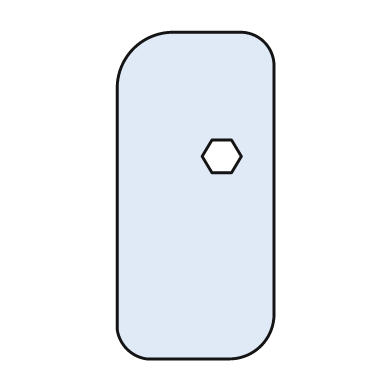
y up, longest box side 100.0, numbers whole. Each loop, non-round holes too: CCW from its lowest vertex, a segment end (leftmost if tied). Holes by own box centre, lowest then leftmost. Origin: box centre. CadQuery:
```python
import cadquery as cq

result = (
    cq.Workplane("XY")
    .moveTo(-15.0, -50.0)
    .lineTo(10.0, -50.0)
    .threePointArc((20.0, -46.0), (24.0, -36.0))
    .lineTo(24.0, 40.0)
    .threePointArc((21.0, 47.0), (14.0, 50.0))
    .lineTo(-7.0, 50.0)
    .threePointArc((-19.0, 45.0), (-24.0, 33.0))
    .lineTo(-24.0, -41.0)
    .threePointArc((-21.0, -47.0), (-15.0, -50.0))
    .close()
    .moveTo(5.0, 7.0)
    .lineTo(11.0, 7.0)
    .lineTo(14.0, 12.0)
    .lineTo(11.0, 17.0)
    .lineTo(5.0, 17.0)
    .lineTo(2.0, 12.0)
    .close()
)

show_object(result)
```